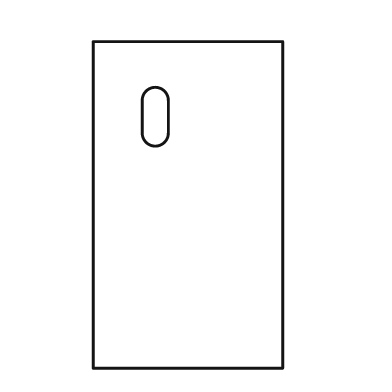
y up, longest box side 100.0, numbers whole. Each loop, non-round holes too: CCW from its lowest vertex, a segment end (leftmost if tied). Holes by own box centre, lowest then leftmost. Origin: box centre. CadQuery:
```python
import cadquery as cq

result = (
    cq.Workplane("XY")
    .moveTo(-29.0, -50.0)
    .lineTo(29.0, -50.0)
    .lineTo(29.0, 50.0)
    .lineTo(-29.0, 50.0)
    .close()
    .moveTo(-14.0, 22.0)
    .threePointArc((-10.0, 18.0), (-6.0, 22.0))
    .lineTo(-6.0, 32.0)
    .threePointArc((-10.0, 36.0), (-14.0, 32.0))
    .close()
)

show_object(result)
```